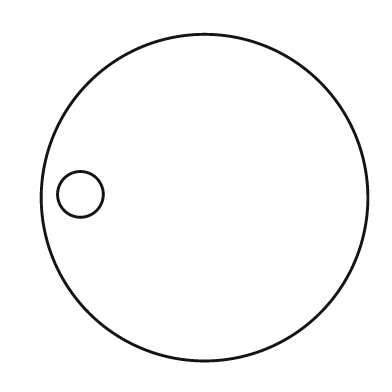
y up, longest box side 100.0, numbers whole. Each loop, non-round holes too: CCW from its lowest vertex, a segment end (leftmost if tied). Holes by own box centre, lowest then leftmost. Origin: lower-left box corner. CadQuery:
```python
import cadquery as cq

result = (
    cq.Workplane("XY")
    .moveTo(50.0, 50.0)
    .circle(50.0)
    .moveTo(12.0, 51.0)
    .circle(7.0)
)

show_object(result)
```